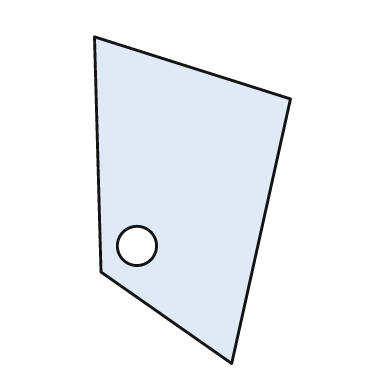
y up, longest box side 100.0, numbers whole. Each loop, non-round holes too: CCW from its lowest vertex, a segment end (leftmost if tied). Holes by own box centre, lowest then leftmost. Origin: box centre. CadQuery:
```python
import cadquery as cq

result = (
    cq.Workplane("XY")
    .moveTo(12.0, -50.0)
    .lineTo(30.0, 31.0)
    .lineTo(-30.0, 50.0)
    .lineTo(-28.0, -22.0)
    .close()
    .moveTo(-17.0, -14.0)
    .circle(6.0)
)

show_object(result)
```